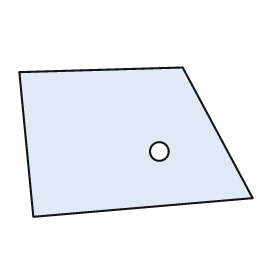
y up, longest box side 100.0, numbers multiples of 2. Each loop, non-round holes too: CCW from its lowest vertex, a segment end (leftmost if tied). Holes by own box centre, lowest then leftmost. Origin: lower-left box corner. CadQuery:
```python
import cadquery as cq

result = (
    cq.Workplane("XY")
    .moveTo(6.0, 0.0)
    .lineTo(100.0, 8.0)
    .lineTo(70.0, 64.0)
    .lineTo(0.0, 62.0)
    .close()
    .moveTo(60.0, 28.0)
    .circle(4.0)
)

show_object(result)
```